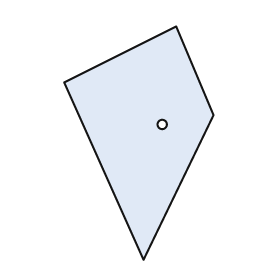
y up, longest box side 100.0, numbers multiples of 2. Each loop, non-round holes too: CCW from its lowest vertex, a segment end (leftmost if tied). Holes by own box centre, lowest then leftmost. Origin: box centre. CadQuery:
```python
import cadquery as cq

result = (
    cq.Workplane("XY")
    .moveTo(2.0, -50.0)
    .lineTo(32.0, 12.0)
    .lineTo(16.0, 50.0)
    .lineTo(-32.0, 26.0)
    .close()
    .moveTo(10.0, 8.0)
    .circle(2.0)
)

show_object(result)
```